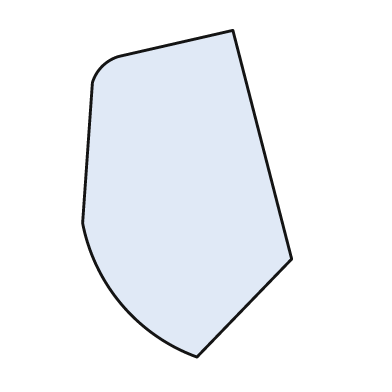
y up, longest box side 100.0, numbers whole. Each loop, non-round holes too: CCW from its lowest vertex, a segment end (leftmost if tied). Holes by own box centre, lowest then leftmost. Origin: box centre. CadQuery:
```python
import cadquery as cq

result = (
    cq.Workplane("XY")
    .moveTo(3.0, -50.0)
    .lineTo(32.0, -20.0)
    .lineTo(14.0, 50.0)
    .lineTo(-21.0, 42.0)
    .threePointArc((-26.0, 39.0), (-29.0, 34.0))
    .lineTo(-32.0, -9.0)
    .threePointArc((-20.0, -34.0), (3.0, -50.0))
    .close()
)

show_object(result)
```